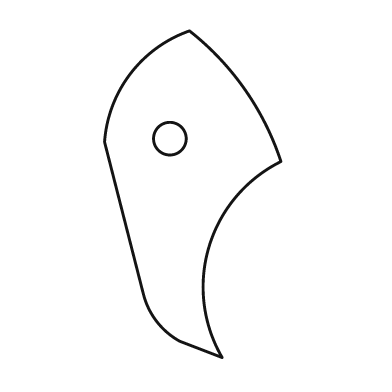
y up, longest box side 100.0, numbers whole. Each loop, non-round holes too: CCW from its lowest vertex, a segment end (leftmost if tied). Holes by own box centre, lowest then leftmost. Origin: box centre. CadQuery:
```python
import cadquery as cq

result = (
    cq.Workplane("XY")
    .moveTo(9.0, -50.0)
    .threePointArc((5.0, -16.0), (27.0, 10.0))
    .threePointArc((16.0, 32.0), (-1.0, 50.0))
    .threePointArc((-19.0, 37.0), (-27.0, 16.0))
    .lineTo(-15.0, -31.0)
    .threePointArc((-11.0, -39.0), (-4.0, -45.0))
    .close()
    .moveTo(-7.0, 17.0)
    .circle(5.0)
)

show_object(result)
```